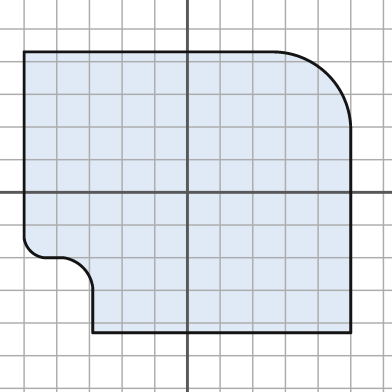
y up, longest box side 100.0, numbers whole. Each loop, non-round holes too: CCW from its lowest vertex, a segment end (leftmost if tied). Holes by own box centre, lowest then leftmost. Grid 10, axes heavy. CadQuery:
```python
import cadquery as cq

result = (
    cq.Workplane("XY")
    .moveTo(-29.0, -43.0)
    .lineTo(50.0, -43.0)
    .lineTo(50.0, 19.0)
    .threePointArc((43.0, 36.0), (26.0, 43.0))
    .lineTo(-50.0, 43.0)
    .lineTo(-50.0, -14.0)
    .threePointArc((-48.0, -18.0), (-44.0, -20.0))
    .lineTo(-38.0, -20.0)
    .threePointArc((-32.0, -23.0), (-29.0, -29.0))
    .close()
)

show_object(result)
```